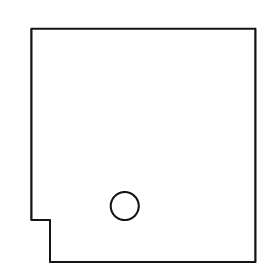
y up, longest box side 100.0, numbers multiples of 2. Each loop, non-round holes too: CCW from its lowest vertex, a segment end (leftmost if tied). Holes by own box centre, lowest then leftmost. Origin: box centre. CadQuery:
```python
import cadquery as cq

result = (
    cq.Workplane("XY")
    .moveTo(-40.0, -50.0)
    .lineTo(48.0, -50.0)
    .lineTo(48.0, 50.0)
    .lineTo(-48.0, 50.0)
    .lineTo(-48.0, -32.0)
    .lineTo(-40.0, -32.0)
    .close()
    .moveTo(-8.0, -26.0)
    .circle(6.0)
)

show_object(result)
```